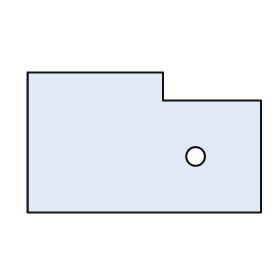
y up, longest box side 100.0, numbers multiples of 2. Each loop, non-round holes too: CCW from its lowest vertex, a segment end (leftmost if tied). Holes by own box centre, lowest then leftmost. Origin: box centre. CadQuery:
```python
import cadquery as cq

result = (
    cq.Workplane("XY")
    .moveTo(-50.0, -30.0)
    .lineTo(50.0, -30.0)
    .lineTo(50.0, 18.0)
    .lineTo(8.0, 18.0)
    .lineTo(8.0, 30.0)
    .lineTo(-50.0, 30.0)
    .close()
    .moveTo(22.0, -6.0)
    .circle(4.0)
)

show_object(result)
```